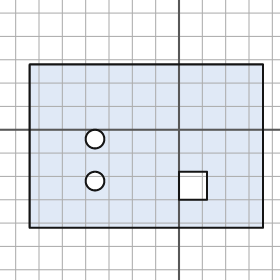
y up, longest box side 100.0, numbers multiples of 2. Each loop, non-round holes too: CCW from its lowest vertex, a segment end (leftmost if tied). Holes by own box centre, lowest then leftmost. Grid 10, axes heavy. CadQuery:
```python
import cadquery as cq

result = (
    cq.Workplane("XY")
    .moveTo(-64.0, -42.0)
    .lineTo(36.0, -42.0)
    .lineTo(36.0, 28.0)
    .lineTo(-64.0, 28.0)
    .close()
    .moveTo(0.0, -30.0)
    .lineTo(12.0, -30.0)
    .lineTo(12.0, -18.0)
    .lineTo(0.0, -18.0)
    .close()
    .moveTo(-36.0, -22.0)
    .circle(4.0)
    .moveTo(-36.0, -4.0)
    .circle(4.0)
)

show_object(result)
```